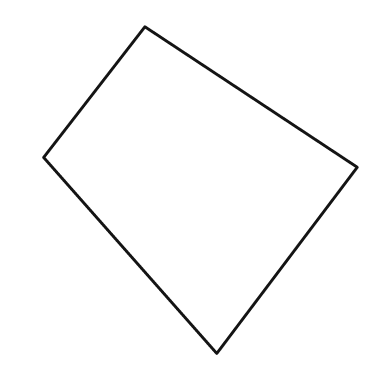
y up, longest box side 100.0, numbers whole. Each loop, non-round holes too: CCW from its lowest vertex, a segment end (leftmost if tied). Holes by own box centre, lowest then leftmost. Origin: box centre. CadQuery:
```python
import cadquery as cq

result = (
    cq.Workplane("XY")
    .moveTo(5.0, -50.0)
    .lineTo(48.0, 7.0)
    .lineTo(-17.0, 50.0)
    .lineTo(-48.0, 10.0)
    .close()
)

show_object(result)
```